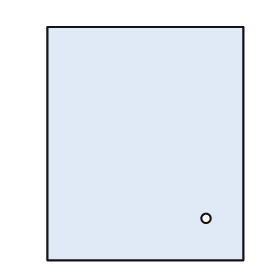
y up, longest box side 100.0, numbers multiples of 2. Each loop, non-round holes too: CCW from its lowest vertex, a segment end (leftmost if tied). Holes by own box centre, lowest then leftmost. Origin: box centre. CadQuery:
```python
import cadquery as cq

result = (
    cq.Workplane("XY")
    .moveTo(-42.0, -50.0)
    .lineTo(42.0, -50.0)
    .lineTo(42.0, 50.0)
    .lineTo(-42.0, 50.0)
    .close()
    .moveTo(26.0, -32.0)
    .circle(2.0)
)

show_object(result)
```